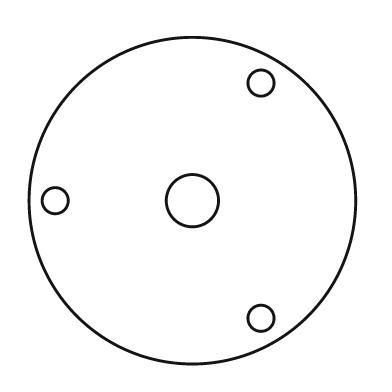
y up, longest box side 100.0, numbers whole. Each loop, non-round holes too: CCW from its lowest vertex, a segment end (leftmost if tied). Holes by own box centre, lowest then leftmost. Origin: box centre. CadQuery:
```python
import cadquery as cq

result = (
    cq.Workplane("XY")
    .moveTo(0.0, 0.0)
    .circle(50.0)
    .moveTo(21.0, -36.0)
    .circle(4.0)
    .moveTo(-42.0, 0.0)
    .circle(4.0)
    .moveTo(0.0, 0.0)
    .circle(8.0)
    .moveTo(21.0, 36.0)
    .circle(4.0)
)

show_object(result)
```